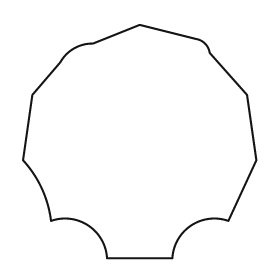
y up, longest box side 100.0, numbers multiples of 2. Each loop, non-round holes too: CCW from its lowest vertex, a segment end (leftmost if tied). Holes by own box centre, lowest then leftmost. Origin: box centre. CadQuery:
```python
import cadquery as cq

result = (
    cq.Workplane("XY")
    .moveTo(-14.0, -50.0)
    .lineTo(14.0, -50.0)
    .threePointArc((22.0, -36.0), (38.0, -34.0))
    .lineTo(50.0, -8.0)
    .lineTo(46.0, 20.0)
    .lineTo(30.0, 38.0)
    .threePointArc((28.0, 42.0), (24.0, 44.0))
    .lineTo(0.0, 50.0)
    .lineTo(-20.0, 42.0)
    .threePointArc((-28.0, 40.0), (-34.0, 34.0))
    .lineTo(-46.0, 20.0)
    .lineTo(-50.0, -8.0)
    .threePointArc((-42.0, -20.0), (-38.0, -34.0))
    .threePointArc((-22.0, -36.0), (-14.0, -50.0))
    .close()
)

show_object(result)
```